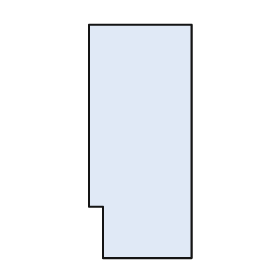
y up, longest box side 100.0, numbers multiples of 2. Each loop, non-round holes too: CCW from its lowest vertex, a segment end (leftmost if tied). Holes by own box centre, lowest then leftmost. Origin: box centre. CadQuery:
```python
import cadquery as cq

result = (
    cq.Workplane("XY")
    .moveTo(-16.0, -50.0)
    .lineTo(22.0, -50.0)
    .lineTo(22.0, 50.0)
    .lineTo(-22.0, 50.0)
    .lineTo(-22.0, -28.0)
    .lineTo(-16.0, -28.0)
    .close()
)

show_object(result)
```